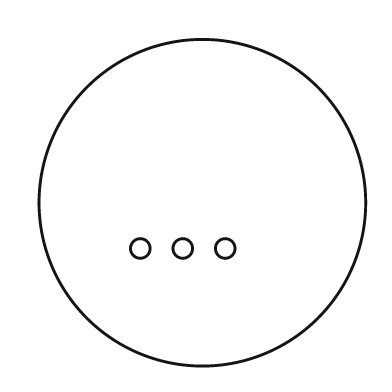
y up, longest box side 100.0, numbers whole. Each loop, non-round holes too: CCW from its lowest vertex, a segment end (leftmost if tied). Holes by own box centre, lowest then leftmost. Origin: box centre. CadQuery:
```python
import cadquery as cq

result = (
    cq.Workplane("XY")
    .moveTo(0.0, 0.0)
    .circle(50.0)
    .moveTo(-19.0, -14.0)
    .circle(3.0)
    .moveTo(-6.0, -14.0)
    .circle(3.0)
    .moveTo(7.0, -14.0)
    .circle(3.0)
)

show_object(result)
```